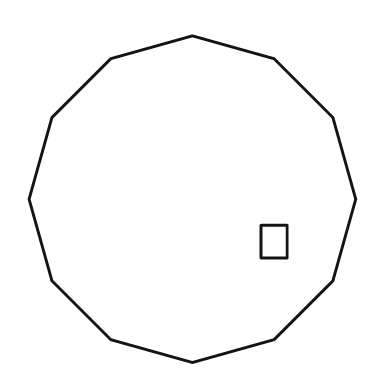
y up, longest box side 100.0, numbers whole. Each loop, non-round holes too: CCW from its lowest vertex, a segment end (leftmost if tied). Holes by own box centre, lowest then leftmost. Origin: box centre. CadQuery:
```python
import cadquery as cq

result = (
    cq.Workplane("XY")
    .moveTo(0.0, -50.0)
    .lineTo(25.0, -43.0)
    .lineTo(43.0, -25.0)
    .lineTo(50.0, 0.0)
    .lineTo(43.0, 25.0)
    .lineTo(25.0, 43.0)
    .lineTo(0.0, 50.0)
    .lineTo(-25.0, 43.0)
    .lineTo(-43.0, 25.0)
    .lineTo(-50.0, 0.0)
    .lineTo(-43.0, -25.0)
    .lineTo(-25.0, -43.0)
    .close()
    .moveTo(21.0, -18.0)
    .lineTo(29.0, -18.0)
    .lineTo(29.0, -8.0)
    .lineTo(21.0, -8.0)
    .close()
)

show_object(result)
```